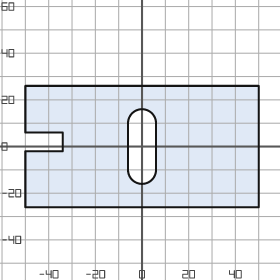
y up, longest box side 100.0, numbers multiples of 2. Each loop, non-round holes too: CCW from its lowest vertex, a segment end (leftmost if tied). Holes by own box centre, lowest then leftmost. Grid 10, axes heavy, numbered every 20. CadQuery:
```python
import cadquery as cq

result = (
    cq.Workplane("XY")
    .moveTo(-50.0, -26.0)
    .lineTo(50.0, -26.0)
    .lineTo(50.0, 26.0)
    .lineTo(-50.0, 26.0)
    .lineTo(-50.0, 6.0)
    .lineTo(-34.0, 6.0)
    .lineTo(-34.0, -2.0)
    .lineTo(-50.0, -2.0)
    .close()
    .moveTo(-6.0, -10.0)
    .threePointArc((0.0, -16.0), (6.0, -10.0))
    .lineTo(6.0, 10.0)
    .threePointArc((0.0, 16.0), (-6.0, 10.0))
    .close()
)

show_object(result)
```